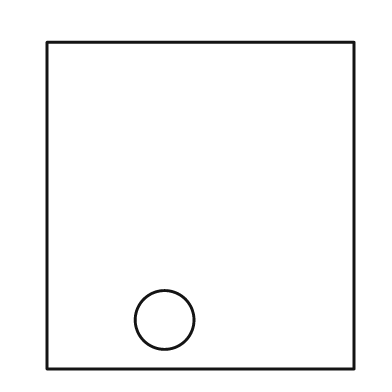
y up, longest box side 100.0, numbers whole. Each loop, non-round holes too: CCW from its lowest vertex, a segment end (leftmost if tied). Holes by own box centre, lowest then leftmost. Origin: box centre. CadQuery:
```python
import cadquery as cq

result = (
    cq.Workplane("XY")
    .moveTo(-47.0, -50.0)
    .lineTo(47.0, -50.0)
    .lineTo(47.0, 50.0)
    .lineTo(-47.0, 50.0)
    .close()
    .moveTo(-11.0, -35.0)
    .circle(9.0)
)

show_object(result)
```